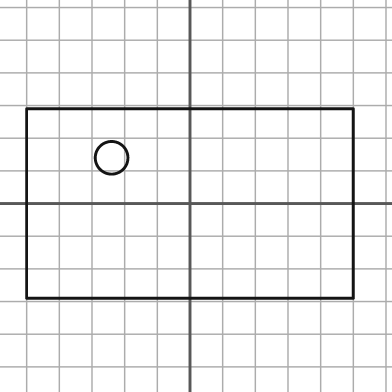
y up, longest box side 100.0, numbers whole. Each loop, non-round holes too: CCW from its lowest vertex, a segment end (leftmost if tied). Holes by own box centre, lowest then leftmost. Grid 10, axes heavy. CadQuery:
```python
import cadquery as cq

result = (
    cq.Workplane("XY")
    .moveTo(-50.0, -29.0)
    .lineTo(50.0, -29.0)
    .lineTo(50.0, 29.0)
    .lineTo(-50.0, 29.0)
    .close()
    .moveTo(-24.0, 14.0)
    .circle(5.0)
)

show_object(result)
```